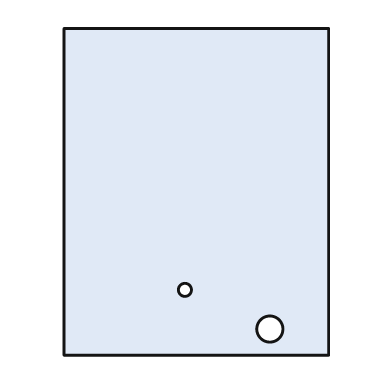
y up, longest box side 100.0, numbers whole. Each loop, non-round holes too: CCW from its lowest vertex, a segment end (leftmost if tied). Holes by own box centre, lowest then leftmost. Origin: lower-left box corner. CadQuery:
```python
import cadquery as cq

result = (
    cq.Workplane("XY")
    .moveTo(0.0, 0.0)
    .lineTo(81.0, 0.0)
    .lineTo(81.0, 100.0)
    .lineTo(0.0, 100.0)
    .close()
    .moveTo(63.0, 8.0)
    .circle(4.0)
    .moveTo(37.0, 20.0)
    .circle(2.0)
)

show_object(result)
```